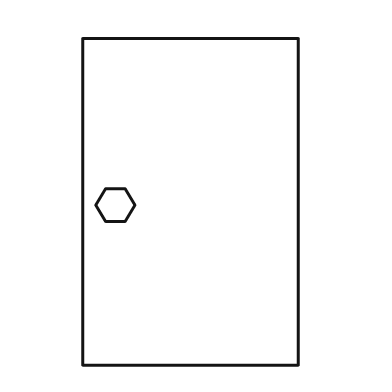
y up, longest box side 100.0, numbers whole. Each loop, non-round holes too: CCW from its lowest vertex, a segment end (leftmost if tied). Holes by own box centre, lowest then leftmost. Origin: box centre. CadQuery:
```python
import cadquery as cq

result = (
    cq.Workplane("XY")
    .moveTo(-33.0, -50.0)
    .lineTo(33.0, -50.0)
    .lineTo(33.0, 50.0)
    .lineTo(-33.0, 50.0)
    .close()
    .moveTo(-26.0, -6.0)
    .lineTo(-20.0, -6.0)
    .lineTo(-17.0, -1.0)
    .lineTo(-20.0, 4.0)
    .lineTo(-26.0, 4.0)
    .lineTo(-29.0, -1.0)
    .close()
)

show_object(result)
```